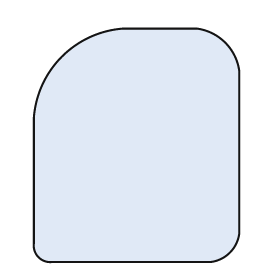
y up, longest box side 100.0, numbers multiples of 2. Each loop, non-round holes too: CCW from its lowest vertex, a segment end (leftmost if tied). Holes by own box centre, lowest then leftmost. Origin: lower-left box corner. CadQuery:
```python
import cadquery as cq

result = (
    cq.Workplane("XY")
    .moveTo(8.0, 0.0)
    .lineTo(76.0, 0.0)
    .threePointArc((84.0, 4.0), (88.0, 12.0))
    .lineTo(88.0, 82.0)
    .threePointArc((82.0, 94.0), (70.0, 100.0))
    .lineTo(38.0, 100.0)
    .threePointArc((12.0, 88.0), (0.0, 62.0))
    .lineTo(0.0, 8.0)
    .threePointArc((2.0, 2.0), (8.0, 0.0))
    .close()
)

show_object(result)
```